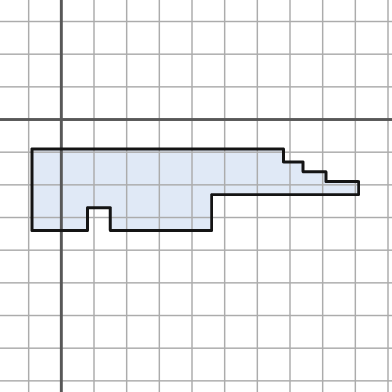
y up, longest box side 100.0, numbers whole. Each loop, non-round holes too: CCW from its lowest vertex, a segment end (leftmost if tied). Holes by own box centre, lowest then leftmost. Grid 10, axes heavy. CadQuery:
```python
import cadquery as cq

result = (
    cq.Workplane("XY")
    .moveTo(-9.0, -34.0)
    .lineTo(8.0, -34.0)
    .lineTo(8.0, -27.0)
    .lineTo(15.0, -27.0)
    .lineTo(15.0, -34.0)
    .lineTo(46.0, -34.0)
    .lineTo(46.0, -23.0)
    .lineTo(91.0, -23.0)
    .lineTo(91.0, -19.0)
    .lineTo(81.0, -19.0)
    .lineTo(81.0, -16.0)
    .lineTo(74.0, -16.0)
    .lineTo(74.0, -13.0)
    .lineTo(68.0, -13.0)
    .lineTo(68.0, -9.0)
    .lineTo(-9.0, -9.0)
    .close()
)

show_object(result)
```